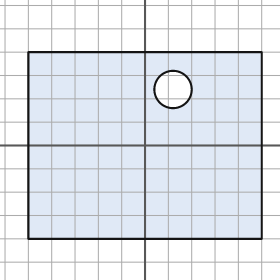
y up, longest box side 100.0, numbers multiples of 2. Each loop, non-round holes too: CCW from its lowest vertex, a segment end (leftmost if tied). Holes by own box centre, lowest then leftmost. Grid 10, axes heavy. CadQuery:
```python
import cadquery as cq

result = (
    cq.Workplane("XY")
    .moveTo(-50.0, -40.0)
    .lineTo(50.0, -40.0)
    .lineTo(50.0, 40.0)
    .lineTo(-50.0, 40.0)
    .close()
    .moveTo(12.0, 24.0)
    .circle(8.0)
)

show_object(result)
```